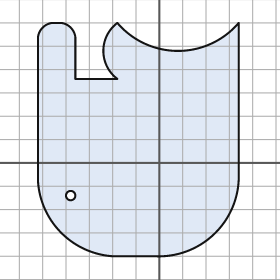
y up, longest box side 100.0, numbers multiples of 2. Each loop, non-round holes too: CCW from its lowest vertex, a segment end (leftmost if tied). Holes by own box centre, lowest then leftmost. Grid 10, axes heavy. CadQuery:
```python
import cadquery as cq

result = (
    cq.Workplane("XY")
    .moveTo(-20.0, -40.0)
    .lineTo(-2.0, -40.0)
    .threePointArc((24.0, -30.0), (34.0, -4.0))
    .lineTo(34.0, 60.0)
    .threePointArc((8.0, 48.0), (-18.0, 60.0))
    .threePointArc((-24.0, 48.0), (-18.0, 36.0))
    .lineTo(-36.0, 36.0)
    .lineTo(-36.0, 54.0)
    .threePointArc((-38.0, 58.0), (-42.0, 60.0))
    .lineTo(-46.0, 60.0)
    .threePointArc((-50.0, 58.0), (-52.0, 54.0))
    .lineTo(-52.0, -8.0)
    .threePointArc((-42.0, -30.0), (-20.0, -40.0))
    .close()
    .moveTo(-38.0, -14.0)
    .circle(2.0)
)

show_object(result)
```